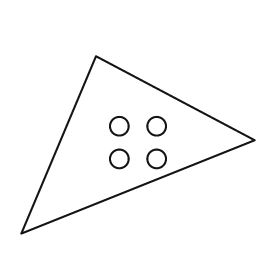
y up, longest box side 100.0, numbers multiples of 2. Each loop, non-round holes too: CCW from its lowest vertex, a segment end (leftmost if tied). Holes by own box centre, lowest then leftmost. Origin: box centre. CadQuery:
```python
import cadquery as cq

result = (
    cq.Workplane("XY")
    .moveTo(-50.0, -38.0)
    .lineTo(50.0, 2.0)
    .lineTo(-18.0, 38.0)
    .close()
    .moveTo(-8.0, -6.0)
    .circle(4.0)
    .moveTo(8.0, -6.0)
    .circle(4.0)
    .moveTo(-8.0, 8.0)
    .circle(4.0)
    .moveTo(8.0, 8.0)
    .circle(4.0)
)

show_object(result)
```